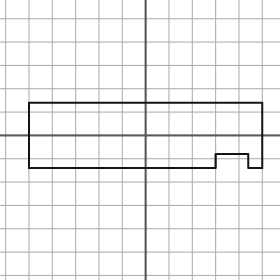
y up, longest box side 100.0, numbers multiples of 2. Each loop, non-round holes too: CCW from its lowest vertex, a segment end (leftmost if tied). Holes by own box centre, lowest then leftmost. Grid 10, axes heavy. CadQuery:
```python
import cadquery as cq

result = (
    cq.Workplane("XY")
    .moveTo(-50.0, -14.0)
    .lineTo(30.0, -14.0)
    .lineTo(30.0, -8.0)
    .lineTo(44.0, -8.0)
    .lineTo(44.0, -14.0)
    .lineTo(50.0, -14.0)
    .lineTo(50.0, 14.0)
    .lineTo(-50.0, 14.0)
    .close()
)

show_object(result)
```